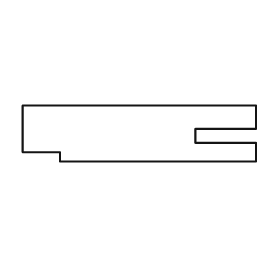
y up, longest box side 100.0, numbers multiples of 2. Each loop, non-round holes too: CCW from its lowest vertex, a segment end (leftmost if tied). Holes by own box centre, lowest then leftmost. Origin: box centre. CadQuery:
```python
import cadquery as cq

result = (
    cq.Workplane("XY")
    .moveTo(-34.0, -12.0)
    .lineTo(50.0, -12.0)
    .lineTo(50.0, -4.0)
    .lineTo(24.0, -4.0)
    .lineTo(24.0, 2.0)
    .lineTo(50.0, 2.0)
    .lineTo(50.0, 12.0)
    .lineTo(-50.0, 12.0)
    .lineTo(-50.0, -8.0)
    .lineTo(-34.0, -8.0)
    .close()
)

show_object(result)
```